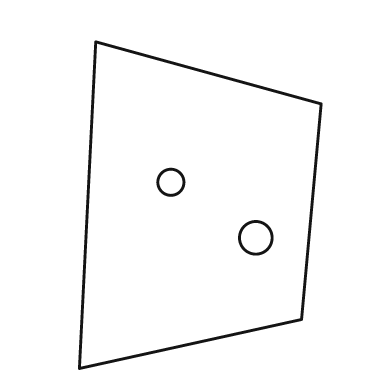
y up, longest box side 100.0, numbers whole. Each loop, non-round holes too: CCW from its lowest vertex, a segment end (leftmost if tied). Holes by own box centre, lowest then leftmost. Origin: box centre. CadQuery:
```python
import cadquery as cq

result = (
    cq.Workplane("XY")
    .moveTo(-37.0, -50.0)
    .lineTo(31.0, -35.0)
    .lineTo(37.0, 31.0)
    .lineTo(-32.0, 50.0)
    .close()
    .moveTo(17.0, -10.0)
    .circle(5.0)
    .moveTo(-9.0, 7.0)
    .circle(4.0)
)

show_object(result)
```